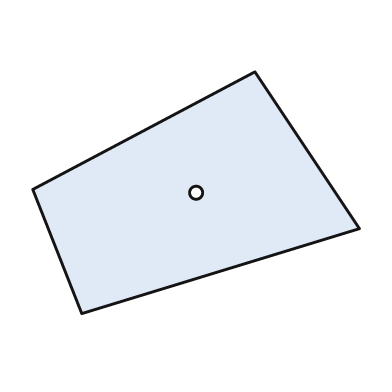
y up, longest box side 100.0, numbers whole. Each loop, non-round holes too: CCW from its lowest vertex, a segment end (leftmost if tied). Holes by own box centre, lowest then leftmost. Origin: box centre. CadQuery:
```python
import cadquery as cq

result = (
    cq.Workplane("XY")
    .moveTo(-35.0, -37.0)
    .lineTo(50.0, -11.0)
    .lineTo(18.0, 37.0)
    .lineTo(-50.0, 1.0)
    .close()
    .moveTo(0.0, 0.0)
    .circle(2.0)
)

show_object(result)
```